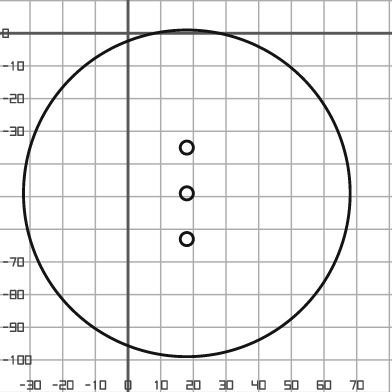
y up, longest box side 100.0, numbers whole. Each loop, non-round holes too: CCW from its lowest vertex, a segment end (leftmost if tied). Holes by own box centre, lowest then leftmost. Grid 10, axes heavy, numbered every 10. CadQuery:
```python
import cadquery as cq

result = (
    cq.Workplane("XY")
    .moveTo(18.0, -49.0)
    .circle(50.0)
    .moveTo(18.0, -63.0)
    .circle(2.0)
    .moveTo(18.0, -49.0)
    .circle(2.0)
    .moveTo(18.0, -35.0)
    .circle(2.0)
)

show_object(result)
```